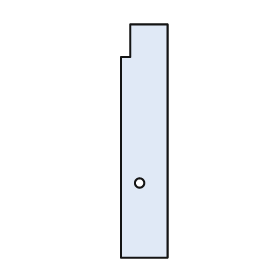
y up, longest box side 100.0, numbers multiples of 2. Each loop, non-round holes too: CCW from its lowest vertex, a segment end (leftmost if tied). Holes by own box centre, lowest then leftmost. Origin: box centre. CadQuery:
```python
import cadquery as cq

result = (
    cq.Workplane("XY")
    .moveTo(-10.0, -50.0)
    .lineTo(10.0, -50.0)
    .lineTo(10.0, 50.0)
    .lineTo(-6.0, 50.0)
    .lineTo(-6.0, 36.0)
    .lineTo(-10.0, 36.0)
    .close()
    .moveTo(-2.0, -18.0)
    .circle(2.0)
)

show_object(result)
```